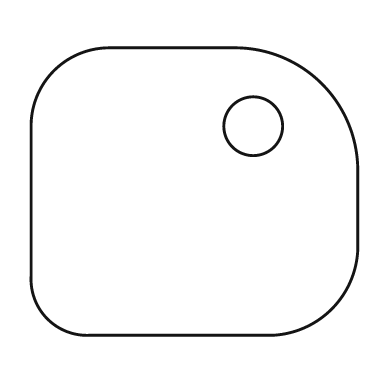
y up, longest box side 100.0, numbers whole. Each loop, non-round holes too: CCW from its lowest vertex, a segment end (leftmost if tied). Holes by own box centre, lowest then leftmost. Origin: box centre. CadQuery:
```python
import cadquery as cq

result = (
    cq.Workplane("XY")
    .moveTo(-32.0, -44.0)
    .lineTo(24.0, -44.0)
    .threePointArc((42.0, -36.0), (50.0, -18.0))
    .lineTo(50.0, 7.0)
    .threePointArc((39.0, 33.0), (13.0, 44.0))
    .lineTo(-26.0, 44.0)
    .threePointArc((-43.0, 37.0), (-50.0, 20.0))
    .lineTo(-50.0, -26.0)
    .threePointArc((-45.0, -39.0), (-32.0, -44.0))
    .close()
    .moveTo(18.0, 20.0)
    .circle(9.0)
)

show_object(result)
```